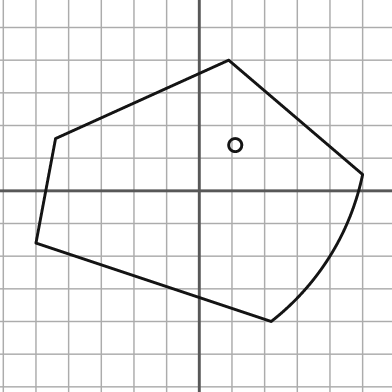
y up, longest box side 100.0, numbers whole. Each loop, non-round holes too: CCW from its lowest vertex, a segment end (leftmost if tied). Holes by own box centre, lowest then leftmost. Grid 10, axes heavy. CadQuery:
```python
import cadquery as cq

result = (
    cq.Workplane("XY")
    .moveTo(22.0, -40.0)
    .threePointArc((40.0, -20.0), (50.0, 5.0))
    .lineTo(9.0, 40.0)
    .lineTo(-44.0, 16.0)
    .lineTo(-50.0, -16.0)
    .close()
    .moveTo(11.0, 14.0)
    .circle(2.0)
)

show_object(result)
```